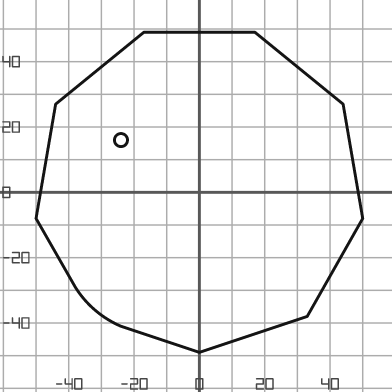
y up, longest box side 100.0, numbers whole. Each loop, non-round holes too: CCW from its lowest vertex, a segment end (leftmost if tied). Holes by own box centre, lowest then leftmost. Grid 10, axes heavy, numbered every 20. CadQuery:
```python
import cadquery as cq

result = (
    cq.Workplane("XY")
    .moveTo(0.0, -49.0)
    .lineTo(33.0, -38.0)
    .lineTo(50.0, -8.0)
    .lineTo(44.0, 27.0)
    .lineTo(17.0, 49.0)
    .lineTo(-17.0, 49.0)
    .lineTo(-44.0, 27.0)
    .lineTo(-50.0, -8.0)
    .lineTo(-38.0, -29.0)
    .threePointArc((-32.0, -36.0), (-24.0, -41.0))
    .close()
    .moveTo(-24.0, 16.0)
    .circle(2.0)
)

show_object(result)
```